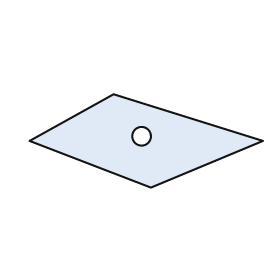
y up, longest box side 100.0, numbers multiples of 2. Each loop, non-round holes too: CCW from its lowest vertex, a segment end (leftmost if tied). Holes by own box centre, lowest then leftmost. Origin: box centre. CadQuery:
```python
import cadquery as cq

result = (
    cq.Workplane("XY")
    .moveTo(2.0, -20.0)
    .lineTo(50.0, 0.0)
    .lineTo(-14.0, 20.0)
    .lineTo(-50.0, 0.0)
    .close()
    .moveTo(-2.0, 2.0)
    .circle(4.0)
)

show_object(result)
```